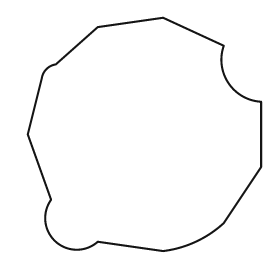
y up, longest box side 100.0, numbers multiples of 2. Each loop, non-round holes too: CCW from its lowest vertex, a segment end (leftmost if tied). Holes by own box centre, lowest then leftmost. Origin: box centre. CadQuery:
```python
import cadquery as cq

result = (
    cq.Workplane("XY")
    .moveTo(8.0, -50.0)
    .threePointArc((22.0, -46.0), (34.0, -38.0))
    .lineTo(50.0, -14.0)
    .lineTo(50.0, 14.0)
    .threePointArc((36.0, 22.0), (34.0, 38.0))
    .lineTo(8.0, 50.0)
    .lineTo(-20.0, 46.0)
    .lineTo(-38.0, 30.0)
    .threePointArc((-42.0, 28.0), (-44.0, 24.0))
    .lineTo(-50.0, 0.0)
    .lineTo(-40.0, -28.0)
    .threePointArc((-38.0, -46.0), (-20.0, -46.0))
    .close()
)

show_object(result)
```